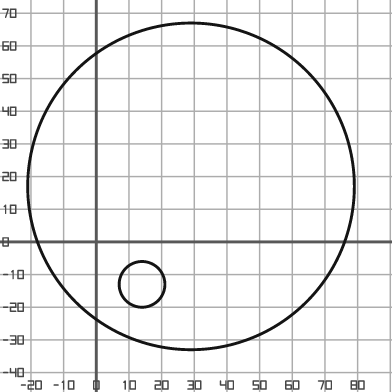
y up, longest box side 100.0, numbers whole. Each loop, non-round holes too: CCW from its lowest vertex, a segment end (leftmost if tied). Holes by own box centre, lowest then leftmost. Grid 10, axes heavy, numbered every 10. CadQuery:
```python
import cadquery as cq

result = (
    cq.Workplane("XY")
    .moveTo(29.0, 17.0)
    .circle(50.0)
    .moveTo(14.0, -13.0)
    .circle(7.0)
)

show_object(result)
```